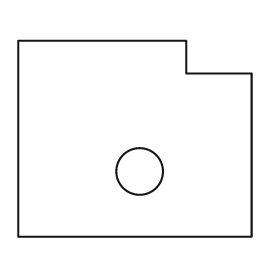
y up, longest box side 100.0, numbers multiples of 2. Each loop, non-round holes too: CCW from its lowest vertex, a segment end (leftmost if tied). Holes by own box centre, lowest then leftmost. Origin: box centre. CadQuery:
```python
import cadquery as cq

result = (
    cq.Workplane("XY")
    .moveTo(-50.0, -42.0)
    .lineTo(50.0, -42.0)
    .lineTo(50.0, 28.0)
    .lineTo(22.0, 28.0)
    .lineTo(22.0, 42.0)
    .lineTo(-50.0, 42.0)
    .close()
    .moveTo(2.0, -14.0)
    .circle(10.0)
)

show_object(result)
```